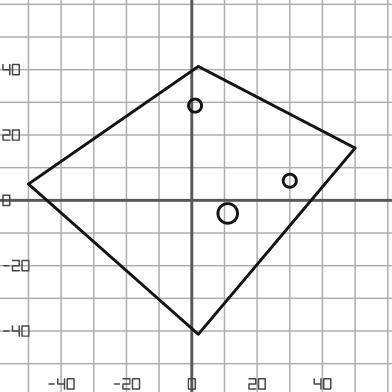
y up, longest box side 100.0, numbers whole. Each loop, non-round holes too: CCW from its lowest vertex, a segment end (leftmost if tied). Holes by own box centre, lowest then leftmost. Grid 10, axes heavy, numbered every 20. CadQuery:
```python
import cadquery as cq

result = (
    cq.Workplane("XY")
    .moveTo(2.0, -41.0)
    .lineTo(50.0, 16.0)
    .lineTo(2.0, 41.0)
    .lineTo(-50.0, 5.0)
    .close()
    .moveTo(11.0, -4.0)
    .circle(3.0)
    .moveTo(30.0, 6.0)
    .circle(2.0)
    .moveTo(1.0, 29.0)
    .circle(2.0)
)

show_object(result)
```